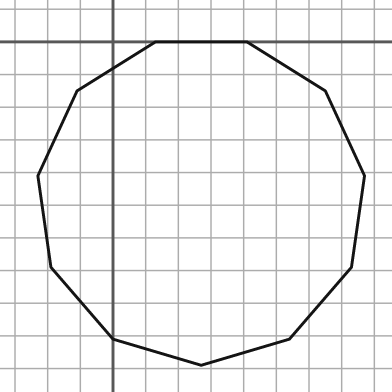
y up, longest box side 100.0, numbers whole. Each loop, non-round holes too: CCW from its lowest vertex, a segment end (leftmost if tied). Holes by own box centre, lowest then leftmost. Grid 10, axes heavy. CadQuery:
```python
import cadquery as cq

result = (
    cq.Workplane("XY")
    .moveTo(27.0, -99.0)
    .lineTo(54.0, -91.0)
    .lineTo(73.0, -69.0)
    .lineTo(77.0, -41.0)
    .lineTo(65.0, -15.0)
    .lineTo(41.0, 0.0)
    .lineTo(13.0, 0.0)
    .lineTo(-11.0, -15.0)
    .lineTo(-23.0, -41.0)
    .lineTo(-19.0, -69.0)
    .lineTo(0.0, -91.0)
    .close()
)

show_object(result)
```